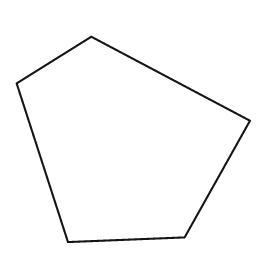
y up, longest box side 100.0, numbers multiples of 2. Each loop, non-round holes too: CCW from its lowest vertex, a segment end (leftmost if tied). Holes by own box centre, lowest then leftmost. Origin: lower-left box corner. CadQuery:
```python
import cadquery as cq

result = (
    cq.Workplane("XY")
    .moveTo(22.0, 0.0)
    .lineTo(72.0, 2.0)
    .lineTo(100.0, 52.0)
    .lineTo(32.0, 88.0)
    .lineTo(0.0, 68.0)
    .close()
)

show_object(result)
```